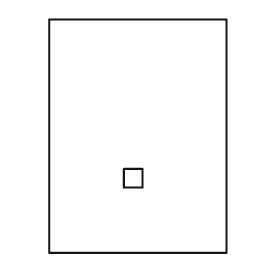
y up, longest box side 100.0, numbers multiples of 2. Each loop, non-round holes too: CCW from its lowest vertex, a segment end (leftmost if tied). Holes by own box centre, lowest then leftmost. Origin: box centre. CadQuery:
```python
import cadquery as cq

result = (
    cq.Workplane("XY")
    .moveTo(-38.0, -50.0)
    .lineTo(38.0, -50.0)
    .lineTo(38.0, 50.0)
    .lineTo(-38.0, 50.0)
    .close()
    .moveTo(-6.0, -22.0)
    .lineTo(2.0, -22.0)
    .lineTo(2.0, -14.0)
    .lineTo(-6.0, -14.0)
    .close()
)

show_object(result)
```